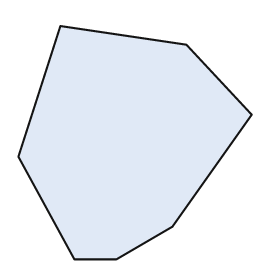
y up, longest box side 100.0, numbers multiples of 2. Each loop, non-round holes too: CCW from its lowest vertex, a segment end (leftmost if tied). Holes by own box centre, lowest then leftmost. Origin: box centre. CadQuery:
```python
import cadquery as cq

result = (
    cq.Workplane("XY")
    .moveTo(-26.0, -50.0)
    .lineTo(-8.0, -50.0)
    .lineTo(16.0, -36.0)
    .lineTo(50.0, 12.0)
    .lineTo(22.0, 42.0)
    .lineTo(-32.0, 50.0)
    .lineTo(-50.0, -6.0)
    .close()
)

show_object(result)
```